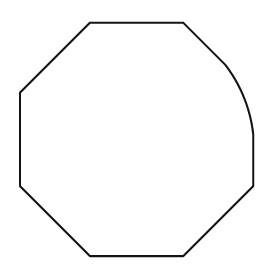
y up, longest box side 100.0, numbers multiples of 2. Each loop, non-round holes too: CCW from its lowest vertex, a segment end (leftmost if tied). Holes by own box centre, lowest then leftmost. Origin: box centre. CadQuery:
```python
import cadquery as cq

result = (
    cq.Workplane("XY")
    .moveTo(-20.0, -50.0)
    .lineTo(20.0, -50.0)
    .lineTo(50.0, -20.0)
    .lineTo(50.0, 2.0)
    .threePointArc((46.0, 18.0), (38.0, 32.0))
    .lineTo(20.0, 50.0)
    .lineTo(-20.0, 50.0)
    .lineTo(-50.0, 20.0)
    .lineTo(-50.0, -20.0)
    .close()
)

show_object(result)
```